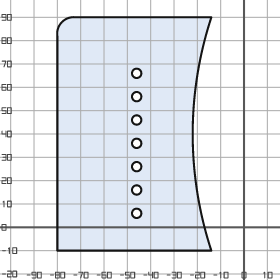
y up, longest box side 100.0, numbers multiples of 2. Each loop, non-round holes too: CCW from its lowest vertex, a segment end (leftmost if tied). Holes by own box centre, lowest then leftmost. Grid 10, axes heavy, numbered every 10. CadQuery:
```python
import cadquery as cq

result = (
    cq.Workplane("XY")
    .moveTo(-80.0, -10.0)
    .lineTo(-14.0, -10.0)
    .threePointArc((-22.0, 40.0), (-14.0, 90.0))
    .lineTo(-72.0, 90.0)
    .threePointArc((-78.0, 88.0), (-80.0, 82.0))
    .close()
    .moveTo(-46.0, 6.0)
    .circle(2.0)
    .moveTo(-46.0, 16.0)
    .circle(2.0)
    .moveTo(-46.0, 26.0)
    .circle(2.0)
    .moveTo(-46.0, 36.0)
    .circle(2.0)
    .moveTo(-46.0, 46.0)
    .circle(2.0)
    .moveTo(-46.0, 56.0)
    .circle(2.0)
    .moveTo(-46.0, 66.0)
    .circle(2.0)
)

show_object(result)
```